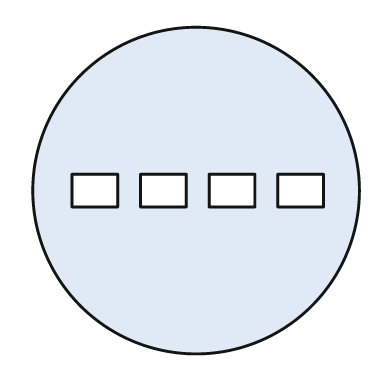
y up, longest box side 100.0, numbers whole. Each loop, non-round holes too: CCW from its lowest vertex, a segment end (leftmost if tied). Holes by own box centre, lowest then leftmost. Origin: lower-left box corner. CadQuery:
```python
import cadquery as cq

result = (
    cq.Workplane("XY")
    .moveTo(50.0, 50.0)
    .circle(50.0)
    .moveTo(12.0, 45.0)
    .lineTo(26.0, 45.0)
    .lineTo(26.0, 55.0)
    .lineTo(12.0, 55.0)
    .close()
    .moveTo(33.0, 45.0)
    .lineTo(47.0, 45.0)
    .lineTo(47.0, 55.0)
    .lineTo(33.0, 55.0)
    .close()
    .moveTo(54.0, 45.0)
    .lineTo(68.0, 45.0)
    .lineTo(68.0, 55.0)
    .lineTo(54.0, 55.0)
    .close()
    .moveTo(75.0, 45.0)
    .lineTo(89.0, 45.0)
    .lineTo(89.0, 55.0)
    .lineTo(75.0, 55.0)
    .close()
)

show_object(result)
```